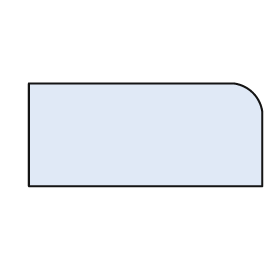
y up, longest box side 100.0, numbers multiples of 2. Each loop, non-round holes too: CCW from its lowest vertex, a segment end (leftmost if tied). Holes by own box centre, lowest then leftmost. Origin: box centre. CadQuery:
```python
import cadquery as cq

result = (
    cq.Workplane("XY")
    .moveTo(-50.0, -22.0)
    .lineTo(50.0, -22.0)
    .lineTo(50.0, 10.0)
    .threePointArc((46.0, 18.0), (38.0, 22.0))
    .lineTo(-50.0, 22.0)
    .close()
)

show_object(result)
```